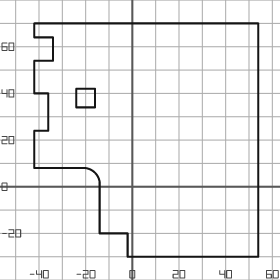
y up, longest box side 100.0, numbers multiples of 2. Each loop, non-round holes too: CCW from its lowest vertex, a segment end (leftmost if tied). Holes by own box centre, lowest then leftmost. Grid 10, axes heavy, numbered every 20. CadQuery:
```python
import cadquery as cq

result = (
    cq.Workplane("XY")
    .moveTo(-2.0, -30.0)
    .lineTo(54.0, -30.0)
    .lineTo(54.0, 70.0)
    .lineTo(-42.0, 70.0)
    .lineTo(-42.0, 64.0)
    .lineTo(-34.0, 64.0)
    .lineTo(-34.0, 54.0)
    .lineTo(-42.0, 54.0)
    .lineTo(-42.0, 40.0)
    .lineTo(-36.0, 40.0)
    .lineTo(-36.0, 24.0)
    .lineTo(-42.0, 24.0)
    .lineTo(-42.0, 8.0)
    .lineTo(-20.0, 8.0)
    .threePointArc((-16.0, 6.0), (-14.0, 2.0))
    .lineTo(-14.0, -20.0)
    .lineTo(-2.0, -20.0)
    .close()
    .moveTo(-24.0, 34.0)
    .lineTo(-16.0, 34.0)
    .lineTo(-16.0, 42.0)
    .lineTo(-24.0, 42.0)
    .close()
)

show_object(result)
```